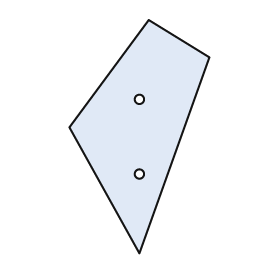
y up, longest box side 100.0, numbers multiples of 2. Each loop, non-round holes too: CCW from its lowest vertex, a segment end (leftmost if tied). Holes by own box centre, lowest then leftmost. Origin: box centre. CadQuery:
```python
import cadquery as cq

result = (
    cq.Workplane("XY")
    .moveTo(0.0, -50.0)
    .lineTo(30.0, 34.0)
    .lineTo(4.0, 50.0)
    .lineTo(-30.0, 4.0)
    .close()
    .moveTo(0.0, -16.0)
    .circle(2.0)
    .moveTo(0.0, 16.0)
    .circle(2.0)
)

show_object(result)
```